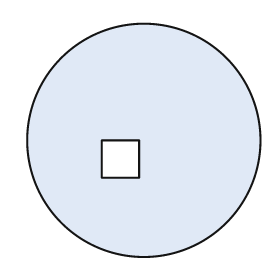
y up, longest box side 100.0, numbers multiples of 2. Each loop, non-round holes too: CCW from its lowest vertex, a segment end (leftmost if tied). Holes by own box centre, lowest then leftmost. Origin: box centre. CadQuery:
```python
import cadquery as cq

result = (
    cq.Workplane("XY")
    .moveTo(0.0, 0.0)
    .circle(50.0)
    .moveTo(-18.0, -16.0)
    .lineTo(-2.0, -16.0)
    .lineTo(-2.0, 0.0)
    .lineTo(-18.0, 0.0)
    .close()
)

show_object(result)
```